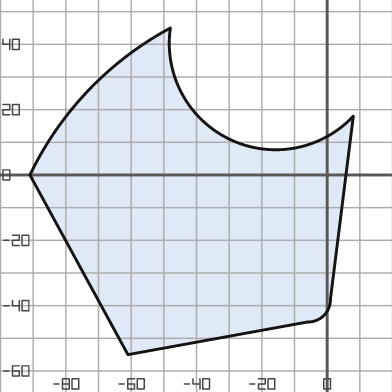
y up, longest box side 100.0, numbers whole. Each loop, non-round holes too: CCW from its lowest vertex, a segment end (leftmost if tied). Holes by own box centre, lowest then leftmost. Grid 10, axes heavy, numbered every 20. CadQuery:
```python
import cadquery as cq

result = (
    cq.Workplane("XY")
    .moveTo(-61.0, -55.0)
    .lineTo(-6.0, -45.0)
    .threePointArc((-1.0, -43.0), (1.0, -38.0))
    .lineTo(8.0, 18.0)
    .threePointArc((-30.0, 11.0), (-48.0, 45.0))
    .threePointArc((-73.0, 26.0), (-91.0, 0.0))
    .close()
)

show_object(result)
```